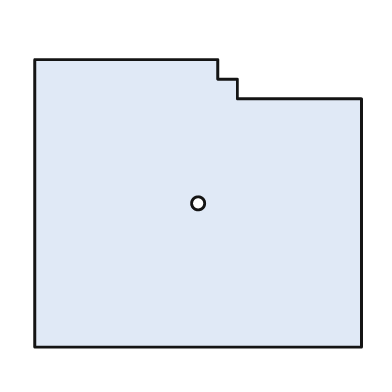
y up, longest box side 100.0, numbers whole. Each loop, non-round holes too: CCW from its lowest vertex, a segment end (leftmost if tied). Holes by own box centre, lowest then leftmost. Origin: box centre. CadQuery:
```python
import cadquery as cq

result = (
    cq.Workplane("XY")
    .moveTo(-50.0, -44.0)
    .lineTo(50.0, -44.0)
    .lineTo(50.0, 32.0)
    .lineTo(12.0, 32.0)
    .lineTo(12.0, 38.0)
    .lineTo(6.0, 38.0)
    .lineTo(6.0, 44.0)
    .lineTo(-50.0, 44.0)
    .close()
    .moveTo(0.0, 0.0)
    .circle(2.0)
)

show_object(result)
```